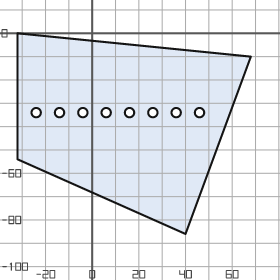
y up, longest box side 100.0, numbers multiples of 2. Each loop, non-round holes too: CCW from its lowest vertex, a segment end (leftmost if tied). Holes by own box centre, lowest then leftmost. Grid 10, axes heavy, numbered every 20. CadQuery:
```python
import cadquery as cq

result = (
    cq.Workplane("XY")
    .moveTo(40.0, -86.0)
    .lineTo(68.0, -10.0)
    .lineTo(-32.0, 0.0)
    .lineTo(-32.0, -54.0)
    .close()
    .moveTo(-24.0, -34.0)
    .circle(2.0)
    .moveTo(-14.0, -34.0)
    .circle(2.0)
    .moveTo(-4.0, -34.0)
    .circle(2.0)
    .moveTo(6.0, -34.0)
    .circle(2.0)
    .moveTo(16.0, -34.0)
    .circle(2.0)
    .moveTo(26.0, -34.0)
    .circle(2.0)
    .moveTo(36.0, -34.0)
    .circle(2.0)
    .moveTo(46.0, -34.0)
    .circle(2.0)
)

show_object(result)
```